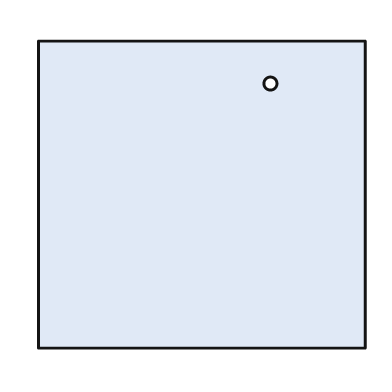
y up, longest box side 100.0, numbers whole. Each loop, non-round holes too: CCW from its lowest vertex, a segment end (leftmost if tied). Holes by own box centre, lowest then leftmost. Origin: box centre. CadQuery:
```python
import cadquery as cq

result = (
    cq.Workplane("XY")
    .moveTo(-50.0, -47.0)
    .lineTo(50.0, -47.0)
    .lineTo(50.0, 47.0)
    .lineTo(-50.0, 47.0)
    .close()
    .moveTo(21.0, 34.0)
    .circle(2.0)
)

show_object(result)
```